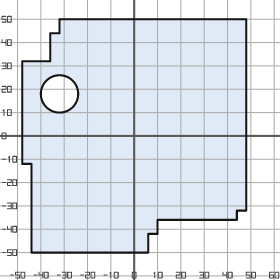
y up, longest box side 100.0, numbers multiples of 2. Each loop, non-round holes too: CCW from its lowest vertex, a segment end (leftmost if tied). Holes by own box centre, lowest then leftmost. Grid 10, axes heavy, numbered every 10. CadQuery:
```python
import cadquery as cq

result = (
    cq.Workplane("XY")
    .moveTo(-44.0, -50.0)
    .lineTo(6.0, -50.0)
    .lineTo(6.0, -42.0)
    .lineTo(10.0, -42.0)
    .lineTo(10.0, -36.0)
    .lineTo(44.0, -36.0)
    .lineTo(44.0, -32.0)
    .lineTo(48.0, -32.0)
    .lineTo(48.0, 50.0)
    .lineTo(-32.0, 50.0)
    .lineTo(-32.0, 44.0)
    .lineTo(-36.0, 44.0)
    .lineTo(-36.0, 32.0)
    .lineTo(-48.0, 32.0)
    .lineTo(-48.0, -12.0)
    .lineTo(-44.0, -12.0)
    .close()
    .moveTo(-32.0, 18.0)
    .circle(8.0)
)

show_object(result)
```